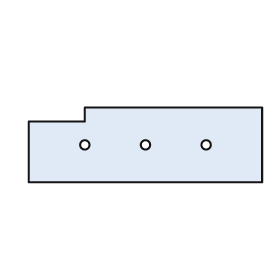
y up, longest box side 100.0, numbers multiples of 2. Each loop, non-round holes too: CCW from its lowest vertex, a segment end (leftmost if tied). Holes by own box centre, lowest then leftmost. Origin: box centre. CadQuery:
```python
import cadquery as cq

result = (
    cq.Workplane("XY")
    .moveTo(-50.0, -16.0)
    .lineTo(50.0, -16.0)
    .lineTo(50.0, 16.0)
    .lineTo(-26.0, 16.0)
    .lineTo(-26.0, 10.0)
    .lineTo(-50.0, 10.0)
    .close()
    .moveTo(-26.0, 0.0)
    .circle(2.0)
    .moveTo(0.0, 0.0)
    .circle(2.0)
    .moveTo(26.0, 0.0)
    .circle(2.0)
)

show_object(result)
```